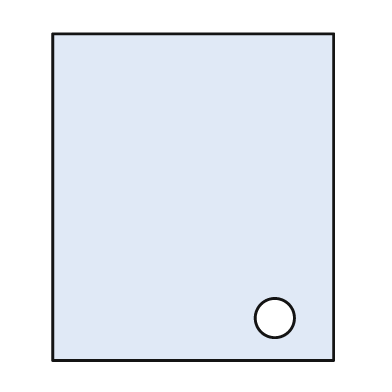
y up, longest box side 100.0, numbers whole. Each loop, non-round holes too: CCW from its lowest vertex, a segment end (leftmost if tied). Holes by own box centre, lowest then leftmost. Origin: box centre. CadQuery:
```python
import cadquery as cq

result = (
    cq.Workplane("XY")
    .moveTo(-43.0, -50.0)
    .lineTo(43.0, -50.0)
    .lineTo(43.0, 50.0)
    .lineTo(-43.0, 50.0)
    .close()
    .moveTo(25.0, -37.0)
    .circle(6.0)
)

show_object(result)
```